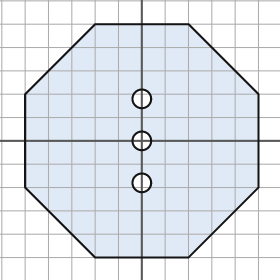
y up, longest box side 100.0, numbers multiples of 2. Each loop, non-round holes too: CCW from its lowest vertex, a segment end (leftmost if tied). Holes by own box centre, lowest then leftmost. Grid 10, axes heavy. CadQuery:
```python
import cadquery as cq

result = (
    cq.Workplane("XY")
    .moveTo(-20.0, -50.0)
    .lineTo(20.0, -50.0)
    .lineTo(50.0, -20.0)
    .lineTo(50.0, 20.0)
    .lineTo(20.0, 50.0)
    .lineTo(-20.0, 50.0)
    .lineTo(-50.0, 20.0)
    .lineTo(-50.0, -20.0)
    .close()
    .moveTo(0.0, -18.0)
    .circle(4.0)
    .moveTo(0.0, 0.0)
    .circle(4.0)
    .moveTo(0.0, 18.0)
    .circle(4.0)
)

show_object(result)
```